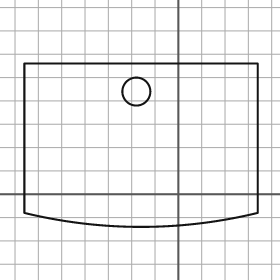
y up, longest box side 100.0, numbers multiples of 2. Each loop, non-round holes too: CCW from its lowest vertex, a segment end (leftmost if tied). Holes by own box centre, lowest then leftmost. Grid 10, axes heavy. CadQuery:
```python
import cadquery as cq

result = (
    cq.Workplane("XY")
    .moveTo(-66.0, -8.0)
    .threePointArc((-16.0, -14.0), (34.0, -8.0))
    .lineTo(34.0, 56.0)
    .lineTo(-66.0, 56.0)
    .close()
    .moveTo(-18.0, 44.0)
    .circle(6.0)
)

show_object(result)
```